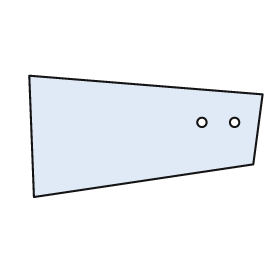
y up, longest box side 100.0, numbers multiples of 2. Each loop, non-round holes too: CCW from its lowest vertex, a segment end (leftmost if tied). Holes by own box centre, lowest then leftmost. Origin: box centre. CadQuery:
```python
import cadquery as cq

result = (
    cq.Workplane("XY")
    .moveTo(-48.0, -26.0)
    .lineTo(46.0, -12.0)
    .lineTo(50.0, 18.0)
    .lineTo(-50.0, 26.0)
    .close()
    .moveTo(24.0, 6.0)
    .circle(2.0)
    .moveTo(38.0, 6.0)
    .circle(2.0)
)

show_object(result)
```